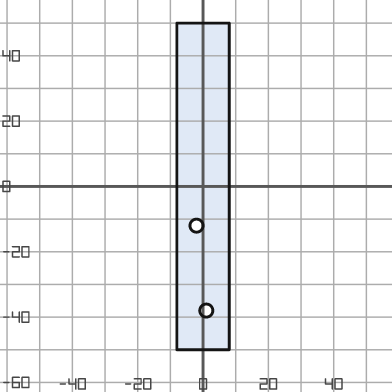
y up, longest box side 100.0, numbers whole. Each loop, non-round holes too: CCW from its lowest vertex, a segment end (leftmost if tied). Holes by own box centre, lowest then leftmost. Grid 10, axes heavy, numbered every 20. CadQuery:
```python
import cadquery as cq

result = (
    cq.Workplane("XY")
    .moveTo(-8.0, -50.0)
    .lineTo(8.0, -50.0)
    .lineTo(8.0, 50.0)
    .lineTo(-8.0, 50.0)
    .close()
    .moveTo(1.0, -38.0)
    .circle(2.0)
    .moveTo(-2.0, -12.0)
    .circle(2.0)
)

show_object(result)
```